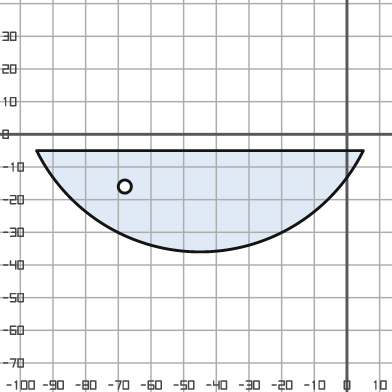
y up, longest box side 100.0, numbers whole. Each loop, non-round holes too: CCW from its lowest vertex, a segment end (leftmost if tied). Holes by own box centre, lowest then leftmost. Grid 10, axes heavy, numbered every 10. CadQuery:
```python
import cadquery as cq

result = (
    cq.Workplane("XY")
    .moveTo(-95.0, -5.0)
    .threePointArc((-45.0, -36.0), (5.0, -5.0))
    .close()
    .moveTo(-68.0, -16.0)
    .circle(2.0)
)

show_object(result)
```